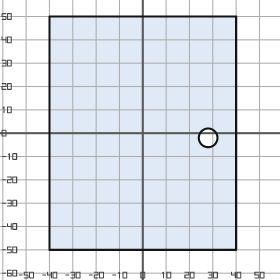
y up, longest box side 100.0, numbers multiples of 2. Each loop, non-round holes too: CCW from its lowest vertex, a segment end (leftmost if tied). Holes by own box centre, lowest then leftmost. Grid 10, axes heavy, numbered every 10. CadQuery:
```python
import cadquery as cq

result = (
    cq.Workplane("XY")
    .moveTo(-40.0, -50.0)
    .lineTo(40.0, -50.0)
    .lineTo(40.0, 50.0)
    .lineTo(-40.0, 50.0)
    .close()
    .moveTo(28.0, -2.0)
    .circle(4.0)
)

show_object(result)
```